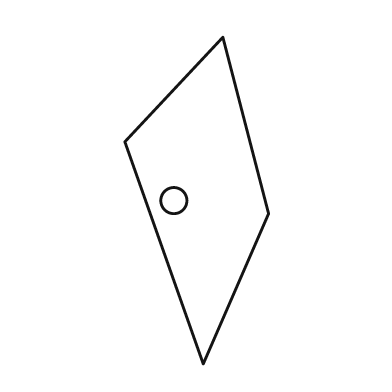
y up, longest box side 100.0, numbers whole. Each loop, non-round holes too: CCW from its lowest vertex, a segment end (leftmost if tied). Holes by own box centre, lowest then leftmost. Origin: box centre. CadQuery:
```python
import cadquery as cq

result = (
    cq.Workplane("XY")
    .moveTo(2.0, -50.0)
    .lineTo(22.0, -4.0)
    .lineTo(8.0, 50.0)
    .lineTo(-22.0, 18.0)
    .close()
    .moveTo(-7.0, 0.0)
    .circle(4.0)
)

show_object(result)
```